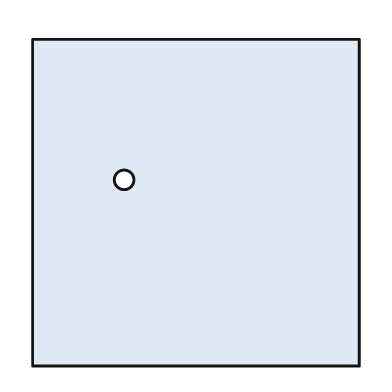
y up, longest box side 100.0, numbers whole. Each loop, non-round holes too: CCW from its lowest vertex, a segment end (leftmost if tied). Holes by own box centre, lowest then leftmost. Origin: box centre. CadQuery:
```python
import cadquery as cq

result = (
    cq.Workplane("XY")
    .moveTo(-50.0, -50.0)
    .lineTo(50.0, -50.0)
    .lineTo(50.0, 50.0)
    .lineTo(-50.0, 50.0)
    .close()
    .moveTo(-22.0, 7.0)
    .circle(3.0)
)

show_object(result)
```